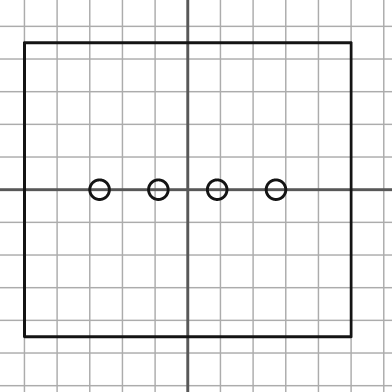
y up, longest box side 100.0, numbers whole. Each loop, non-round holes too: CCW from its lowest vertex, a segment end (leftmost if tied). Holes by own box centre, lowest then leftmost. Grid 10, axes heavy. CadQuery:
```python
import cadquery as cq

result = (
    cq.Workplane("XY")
    .moveTo(-50.0, -45.0)
    .lineTo(50.0, -45.0)
    .lineTo(50.0, 45.0)
    .lineTo(-50.0, 45.0)
    .close()
    .moveTo(-27.0, 0.0)
    .circle(3.0)
    .moveTo(-9.0, 0.0)
    .circle(3.0)
    .moveTo(9.0, 0.0)
    .circle(3.0)
    .moveTo(27.0, 0.0)
    .circle(3.0)
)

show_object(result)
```